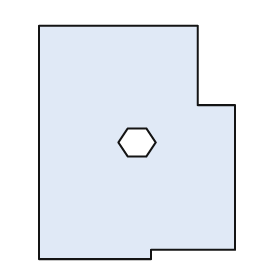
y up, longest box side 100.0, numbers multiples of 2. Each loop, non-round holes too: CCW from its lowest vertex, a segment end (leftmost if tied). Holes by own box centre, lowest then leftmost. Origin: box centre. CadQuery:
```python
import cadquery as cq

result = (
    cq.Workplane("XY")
    .moveTo(-42.0, -50.0)
    .lineTo(6.0, -50.0)
    .lineTo(6.0, -46.0)
    .lineTo(42.0, -46.0)
    .lineTo(42.0, 16.0)
    .lineTo(26.0, 16.0)
    .lineTo(26.0, 50.0)
    .lineTo(-42.0, 50.0)
    .close()
    .moveTo(-4.0, -6.0)
    .lineTo(4.0, -6.0)
    .lineTo(8.0, 0.0)
    .lineTo(4.0, 6.0)
    .lineTo(-4.0, 6.0)
    .lineTo(-8.0, 0.0)
    .close()
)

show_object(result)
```